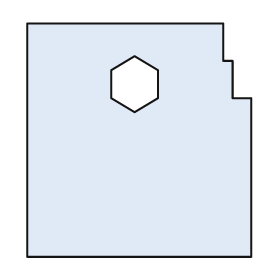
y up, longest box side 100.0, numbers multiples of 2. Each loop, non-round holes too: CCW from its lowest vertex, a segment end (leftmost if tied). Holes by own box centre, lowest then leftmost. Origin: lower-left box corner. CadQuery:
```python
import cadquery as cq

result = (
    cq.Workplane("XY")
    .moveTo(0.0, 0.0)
    .lineTo(96.0, 0.0)
    .lineTo(96.0, 68.0)
    .lineTo(88.0, 68.0)
    .lineTo(88.0, 84.0)
    .lineTo(84.0, 84.0)
    .lineTo(84.0, 100.0)
    .lineTo(0.0, 100.0)
    .close()
    .moveTo(46.0, 62.0)
    .lineTo(56.0, 68.0)
    .lineTo(56.0, 80.0)
    .lineTo(46.0, 86.0)
    .lineTo(36.0, 80.0)
    .lineTo(36.0, 68.0)
    .close()
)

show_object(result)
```